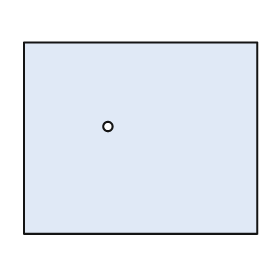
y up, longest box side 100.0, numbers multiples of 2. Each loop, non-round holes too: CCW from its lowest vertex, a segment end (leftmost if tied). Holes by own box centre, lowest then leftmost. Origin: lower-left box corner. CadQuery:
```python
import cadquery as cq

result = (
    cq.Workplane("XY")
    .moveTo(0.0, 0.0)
    .lineTo(100.0, 0.0)
    .lineTo(100.0, 82.0)
    .lineTo(0.0, 82.0)
    .close()
    .moveTo(36.0, 46.0)
    .circle(2.0)
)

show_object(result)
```